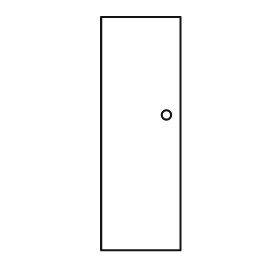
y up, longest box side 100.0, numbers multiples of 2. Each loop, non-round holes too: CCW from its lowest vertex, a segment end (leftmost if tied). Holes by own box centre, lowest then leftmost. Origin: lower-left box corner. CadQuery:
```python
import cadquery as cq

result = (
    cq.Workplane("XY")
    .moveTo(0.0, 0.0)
    .lineTo(34.0, 0.0)
    .lineTo(34.0, 100.0)
    .lineTo(0.0, 100.0)
    .close()
    .moveTo(28.0, 58.0)
    .circle(2.0)
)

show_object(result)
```